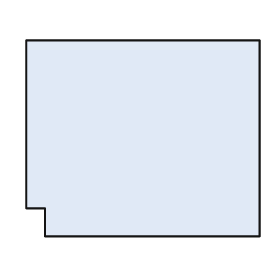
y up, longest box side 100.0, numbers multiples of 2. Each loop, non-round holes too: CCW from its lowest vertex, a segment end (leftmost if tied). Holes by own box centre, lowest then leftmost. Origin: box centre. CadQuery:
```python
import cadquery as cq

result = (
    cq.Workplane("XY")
    .moveTo(-42.0, -42.0)
    .lineTo(50.0, -42.0)
    .lineTo(50.0, 42.0)
    .lineTo(-50.0, 42.0)
    .lineTo(-50.0, -30.0)
    .lineTo(-42.0, -30.0)
    .close()
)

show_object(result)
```